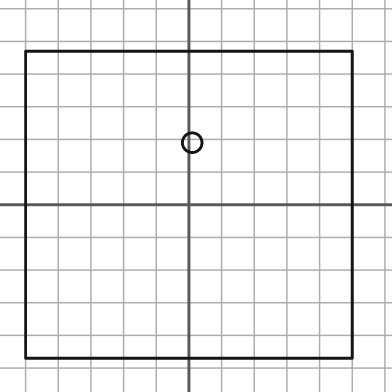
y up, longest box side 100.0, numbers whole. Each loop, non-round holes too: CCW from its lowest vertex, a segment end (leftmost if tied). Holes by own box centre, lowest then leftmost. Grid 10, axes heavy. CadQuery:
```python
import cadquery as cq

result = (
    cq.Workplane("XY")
    .moveTo(-50.0, -47.0)
    .lineTo(50.0, -47.0)
    .lineTo(50.0, 47.0)
    .lineTo(-50.0, 47.0)
    .close()
    .moveTo(1.0, 19.0)
    .circle(3.0)
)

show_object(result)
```